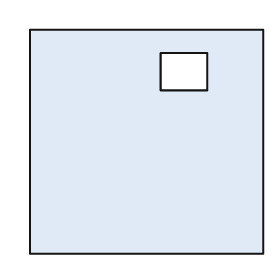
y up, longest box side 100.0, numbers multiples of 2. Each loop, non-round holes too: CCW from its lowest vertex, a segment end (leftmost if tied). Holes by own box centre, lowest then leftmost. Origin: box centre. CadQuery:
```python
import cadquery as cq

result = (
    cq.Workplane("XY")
    .moveTo(-50.0, -48.0)
    .lineTo(50.0, -48.0)
    .lineTo(50.0, 48.0)
    .lineTo(-50.0, 48.0)
    .close()
    .moveTo(6.0, 22.0)
    .lineTo(26.0, 22.0)
    .lineTo(26.0, 38.0)
    .lineTo(6.0, 38.0)
    .close()
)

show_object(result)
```